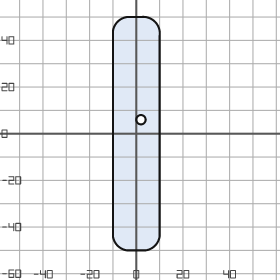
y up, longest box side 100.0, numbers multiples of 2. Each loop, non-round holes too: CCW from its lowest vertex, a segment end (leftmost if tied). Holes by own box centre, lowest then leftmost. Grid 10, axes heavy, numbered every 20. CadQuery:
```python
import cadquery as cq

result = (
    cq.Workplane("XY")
    .moveTo(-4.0, -50.0)
    .lineTo(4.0, -50.0)
    .threePointArc((8.0, -48.0), (10.0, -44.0))
    .lineTo(10.0, 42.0)
    .threePointArc((8.0, 48.0), (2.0, 50.0))
    .lineTo(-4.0, 50.0)
    .threePointArc((-8.0, 48.0), (-10.0, 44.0))
    .lineTo(-10.0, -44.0)
    .threePointArc((-8.0, -48.0), (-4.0, -50.0))
    .close()
    .moveTo(2.0, 6.0)
    .circle(2.0)
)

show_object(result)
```